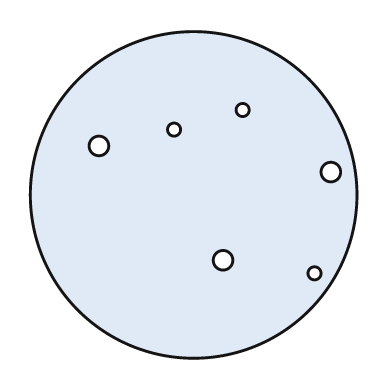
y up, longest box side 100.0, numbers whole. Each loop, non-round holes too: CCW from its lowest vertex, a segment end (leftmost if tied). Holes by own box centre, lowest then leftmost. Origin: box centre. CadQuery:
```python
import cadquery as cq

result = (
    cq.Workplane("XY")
    .moveTo(0.0, 0.0)
    .circle(50.0)
    .moveTo(37.0, -24.0)
    .circle(2.0)
    .moveTo(9.0, -20.0)
    .circle(3.0)
    .moveTo(42.0, 7.0)
    .circle(3.0)
    .moveTo(-29.0, 15.0)
    .circle(3.0)
    .moveTo(-6.0, 20.0)
    .circle(2.0)
    .moveTo(15.0, 26.0)
    .circle(2.0)
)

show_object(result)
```